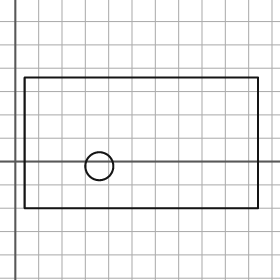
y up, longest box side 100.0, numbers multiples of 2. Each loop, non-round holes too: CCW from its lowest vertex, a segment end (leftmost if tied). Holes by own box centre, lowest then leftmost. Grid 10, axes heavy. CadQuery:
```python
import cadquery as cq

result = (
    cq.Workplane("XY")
    .moveTo(4.0, -20.0)
    .lineTo(104.0, -20.0)
    .lineTo(104.0, 36.0)
    .lineTo(4.0, 36.0)
    .close()
    .moveTo(36.0, -2.0)
    .circle(6.0)
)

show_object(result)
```